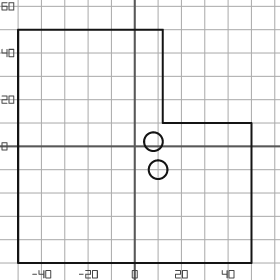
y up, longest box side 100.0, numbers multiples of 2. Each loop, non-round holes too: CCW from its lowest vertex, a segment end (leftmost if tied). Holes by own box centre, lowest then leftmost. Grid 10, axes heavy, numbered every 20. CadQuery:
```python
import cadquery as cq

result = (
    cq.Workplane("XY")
    .moveTo(-50.0, -50.0)
    .lineTo(50.0, -50.0)
    .lineTo(50.0, 10.0)
    .lineTo(12.0, 10.0)
    .lineTo(12.0, 50.0)
    .lineTo(-50.0, 50.0)
    .close()
    .moveTo(10.0, -10.0)
    .circle(4.0)
    .moveTo(8.0, 2.0)
    .circle(4.0)
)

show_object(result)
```